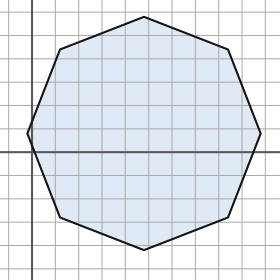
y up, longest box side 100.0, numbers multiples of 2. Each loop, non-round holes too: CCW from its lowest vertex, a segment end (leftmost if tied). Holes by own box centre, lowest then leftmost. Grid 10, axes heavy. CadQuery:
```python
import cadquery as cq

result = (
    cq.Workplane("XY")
    .moveTo(48.0, -42.0)
    .lineTo(84.0, -28.0)
    .lineTo(98.0, 8.0)
    .lineTo(84.0, 44.0)
    .lineTo(48.0, 58.0)
    .lineTo(12.0, 44.0)
    .lineTo(-2.0, 8.0)
    .lineTo(12.0, -28.0)
    .close()
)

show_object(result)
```